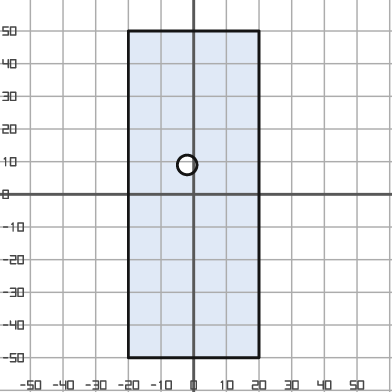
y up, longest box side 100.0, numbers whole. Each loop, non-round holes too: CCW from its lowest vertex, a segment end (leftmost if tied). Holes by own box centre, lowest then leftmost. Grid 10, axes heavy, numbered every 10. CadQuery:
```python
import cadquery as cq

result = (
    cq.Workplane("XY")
    .moveTo(-20.0, -50.0)
    .lineTo(20.0, -50.0)
    .lineTo(20.0, 50.0)
    .lineTo(-20.0, 50.0)
    .close()
    .moveTo(-2.0, 9.0)
    .circle(3.0)
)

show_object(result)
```